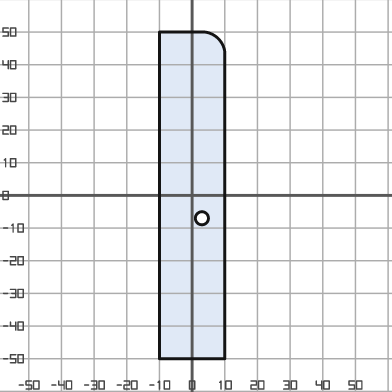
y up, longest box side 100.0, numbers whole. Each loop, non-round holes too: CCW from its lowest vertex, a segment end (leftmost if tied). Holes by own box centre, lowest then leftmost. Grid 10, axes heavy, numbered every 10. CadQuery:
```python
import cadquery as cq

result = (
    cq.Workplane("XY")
    .moveTo(-10.0, -50.0)
    .lineTo(10.0, -50.0)
    .lineTo(10.0, 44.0)
    .threePointArc((8.0, 48.0), (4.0, 50.0))
    .lineTo(-10.0, 50.0)
    .close()
    .moveTo(3.0, -7.0)
    .circle(2.0)
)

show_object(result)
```